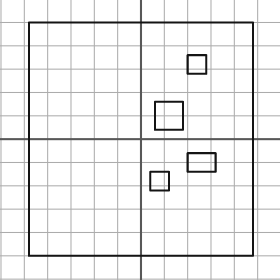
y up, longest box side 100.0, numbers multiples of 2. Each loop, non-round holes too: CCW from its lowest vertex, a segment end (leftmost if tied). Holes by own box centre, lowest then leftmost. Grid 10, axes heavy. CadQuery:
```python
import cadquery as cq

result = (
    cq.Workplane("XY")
    .moveTo(-48.0, -50.0)
    .lineTo(48.0, -50.0)
    .lineTo(48.0, 50.0)
    .lineTo(-48.0, 50.0)
    .close()
    .moveTo(4.0, -22.0)
    .lineTo(12.0, -22.0)
    .lineTo(12.0, -14.0)
    .lineTo(4.0, -14.0)
    .close()
    .moveTo(20.0, -14.0)
    .lineTo(32.0, -14.0)
    .lineTo(32.0, -6.0)
    .lineTo(20.0, -6.0)
    .close()
    .moveTo(6.0, 4.0)
    .lineTo(18.0, 4.0)
    .lineTo(18.0, 16.0)
    .lineTo(6.0, 16.0)
    .close()
    .moveTo(20.0, 28.0)
    .lineTo(28.0, 28.0)
    .lineTo(28.0, 36.0)
    .lineTo(20.0, 36.0)
    .close()
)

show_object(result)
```